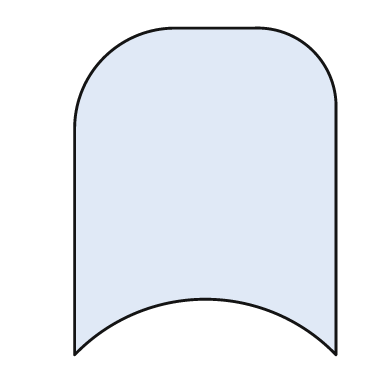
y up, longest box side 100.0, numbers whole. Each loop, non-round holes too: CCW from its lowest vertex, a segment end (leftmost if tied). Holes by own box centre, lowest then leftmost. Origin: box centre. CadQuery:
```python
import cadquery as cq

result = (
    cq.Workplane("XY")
    .moveTo(-40.0, -50.0)
    .threePointArc((0.0, -33.0), (40.0, -50.0))
    .lineTo(40.0, 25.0)
    .threePointArc((33.0, 43.0), (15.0, 50.0))
    .lineTo(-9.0, 50.0)
    .threePointArc((-31.0, 41.0), (-40.0, 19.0))
    .close()
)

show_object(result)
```